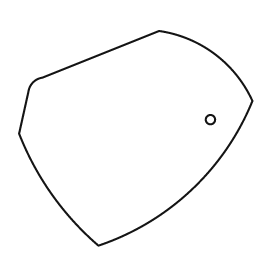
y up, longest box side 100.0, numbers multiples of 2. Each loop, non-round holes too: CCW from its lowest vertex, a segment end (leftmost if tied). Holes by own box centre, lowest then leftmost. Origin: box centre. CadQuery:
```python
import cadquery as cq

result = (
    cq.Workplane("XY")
    .moveTo(-16.0, -46.0)
    .threePointArc((24.0, -22.0), (50.0, 16.0))
    .threePointArc((34.0, 36.0), (10.0, 46.0))
    .lineTo(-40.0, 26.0)
    .threePointArc((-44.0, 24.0), (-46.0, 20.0))
    .lineTo(-50.0, 2.0)
    .threePointArc((-36.0, -24.0), (-16.0, -46.0))
    .close()
    .moveTo(32.0, 8.0)
    .circle(2.0)
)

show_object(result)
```